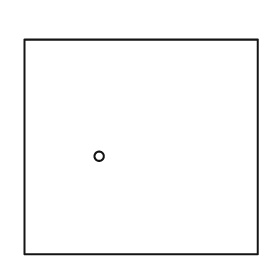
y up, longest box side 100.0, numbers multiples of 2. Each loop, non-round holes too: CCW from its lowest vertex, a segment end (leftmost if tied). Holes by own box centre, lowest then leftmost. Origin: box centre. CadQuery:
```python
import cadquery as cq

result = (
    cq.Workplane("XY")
    .moveTo(-50.0, -46.0)
    .lineTo(50.0, -46.0)
    .lineTo(50.0, 46.0)
    .lineTo(-50.0, 46.0)
    .close()
    .moveTo(-18.0, -4.0)
    .circle(2.0)
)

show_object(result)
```